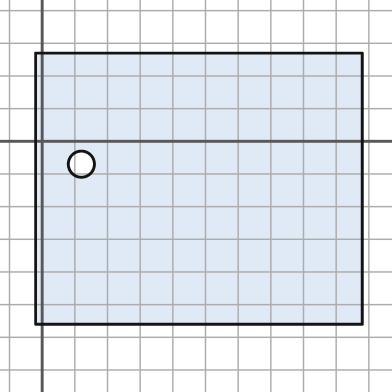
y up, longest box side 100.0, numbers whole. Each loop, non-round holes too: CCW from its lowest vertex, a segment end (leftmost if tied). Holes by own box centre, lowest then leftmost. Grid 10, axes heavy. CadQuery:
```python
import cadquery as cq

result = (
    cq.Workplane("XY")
    .moveTo(-2.0, -56.0)
    .lineTo(98.0, -56.0)
    .lineTo(98.0, 27.0)
    .lineTo(-2.0, 27.0)
    .close()
    .moveTo(12.0, -7.0)
    .circle(4.0)
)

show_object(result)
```